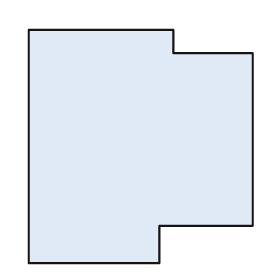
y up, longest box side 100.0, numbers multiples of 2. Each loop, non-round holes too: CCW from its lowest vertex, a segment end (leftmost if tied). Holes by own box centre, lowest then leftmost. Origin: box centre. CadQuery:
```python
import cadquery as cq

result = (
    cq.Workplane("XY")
    .moveTo(-48.0, -50.0)
    .lineTo(8.0, -50.0)
    .lineTo(8.0, -34.0)
    .lineTo(48.0, -34.0)
    .lineTo(48.0, 40.0)
    .lineTo(14.0, 40.0)
    .lineTo(14.0, 50.0)
    .lineTo(-48.0, 50.0)
    .close()
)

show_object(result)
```